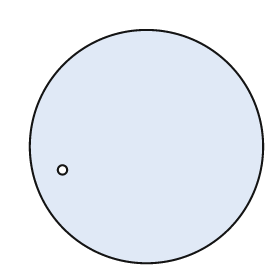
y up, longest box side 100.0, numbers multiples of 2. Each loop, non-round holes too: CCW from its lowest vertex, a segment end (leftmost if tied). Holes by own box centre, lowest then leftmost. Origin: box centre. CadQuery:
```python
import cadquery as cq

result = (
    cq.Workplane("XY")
    .moveTo(0.0, 0.0)
    .circle(50.0)
    .moveTo(-36.0, -10.0)
    .circle(2.0)
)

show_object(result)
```